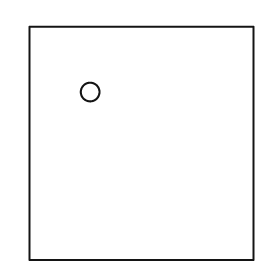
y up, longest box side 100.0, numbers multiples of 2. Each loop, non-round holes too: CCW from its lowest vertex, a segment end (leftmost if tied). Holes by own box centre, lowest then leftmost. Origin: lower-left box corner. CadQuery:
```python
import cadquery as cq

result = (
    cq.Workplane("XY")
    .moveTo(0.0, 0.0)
    .lineTo(96.0, 0.0)
    .lineTo(96.0, 100.0)
    .lineTo(0.0, 100.0)
    .close()
    .moveTo(26.0, 72.0)
    .circle(4.0)
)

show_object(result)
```